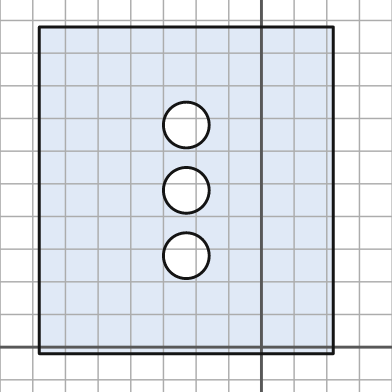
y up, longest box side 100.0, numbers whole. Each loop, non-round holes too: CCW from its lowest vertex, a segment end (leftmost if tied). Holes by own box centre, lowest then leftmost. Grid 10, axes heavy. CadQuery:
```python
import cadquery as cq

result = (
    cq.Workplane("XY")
    .moveTo(-68.0, -2.0)
    .lineTo(22.0, -2.0)
    .lineTo(22.0, 98.0)
    .lineTo(-68.0, 98.0)
    .close()
    .moveTo(-23.0, 28.0)
    .circle(7.0)
    .moveTo(-23.0, 48.0)
    .circle(7.0)
    .moveTo(-23.0, 68.0)
    .circle(7.0)
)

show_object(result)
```